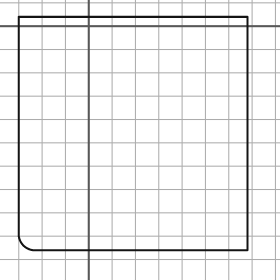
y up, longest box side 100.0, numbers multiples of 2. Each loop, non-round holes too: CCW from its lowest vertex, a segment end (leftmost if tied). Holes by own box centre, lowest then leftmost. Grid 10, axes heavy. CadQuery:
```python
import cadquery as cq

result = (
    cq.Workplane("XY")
    .moveTo(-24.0, -96.0)
    .lineTo(68.0, -96.0)
    .lineTo(68.0, 4.0)
    .lineTo(-30.0, 4.0)
    .lineTo(-30.0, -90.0)
    .threePointArc((-28.0, -94.0), (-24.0, -96.0))
    .close()
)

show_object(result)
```